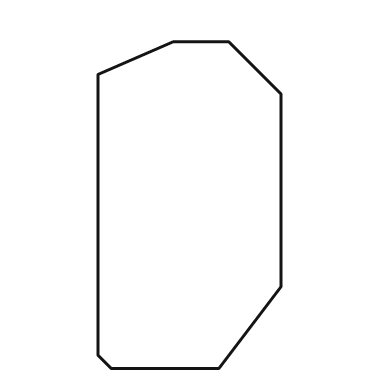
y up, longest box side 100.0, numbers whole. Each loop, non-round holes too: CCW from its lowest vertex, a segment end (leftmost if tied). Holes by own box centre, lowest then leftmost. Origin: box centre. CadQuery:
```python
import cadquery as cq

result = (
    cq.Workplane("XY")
    .moveTo(-24.0, -50.0)
    .lineTo(9.0, -50.0)
    .lineTo(28.0, -25.0)
    .lineTo(28.0, 34.0)
    .lineTo(12.0, 50.0)
    .lineTo(-5.0, 50.0)
    .lineTo(-28.0, 40.0)
    .lineTo(-28.0, -46.0)
    .close()
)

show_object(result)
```